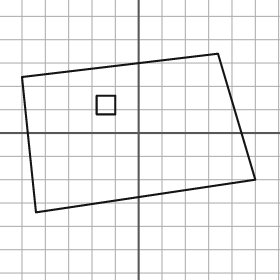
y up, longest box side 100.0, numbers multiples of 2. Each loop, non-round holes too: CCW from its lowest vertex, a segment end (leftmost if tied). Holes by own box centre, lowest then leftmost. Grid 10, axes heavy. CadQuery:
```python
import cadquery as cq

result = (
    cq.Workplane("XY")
    .moveTo(-44.0, -34.0)
    .lineTo(50.0, -20.0)
    .lineTo(34.0, 34.0)
    .lineTo(-50.0, 24.0)
    .close()
    .moveTo(-18.0, 8.0)
    .lineTo(-10.0, 8.0)
    .lineTo(-10.0, 16.0)
    .lineTo(-18.0, 16.0)
    .close()
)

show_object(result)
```